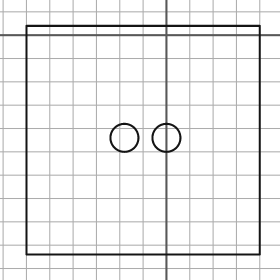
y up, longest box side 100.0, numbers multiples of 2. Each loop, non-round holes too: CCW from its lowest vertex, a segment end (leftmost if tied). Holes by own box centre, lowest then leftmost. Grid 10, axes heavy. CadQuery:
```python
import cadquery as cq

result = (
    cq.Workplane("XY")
    .moveTo(-60.0, -94.0)
    .lineTo(40.0, -94.0)
    .lineTo(40.0, 4.0)
    .lineTo(-60.0, 4.0)
    .close()
    .moveTo(-18.0, -44.0)
    .circle(6.0)
    .moveTo(0.0, -44.0)
    .circle(6.0)
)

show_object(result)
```